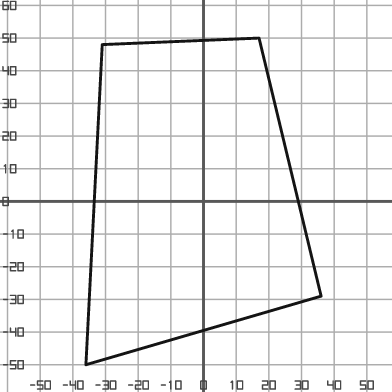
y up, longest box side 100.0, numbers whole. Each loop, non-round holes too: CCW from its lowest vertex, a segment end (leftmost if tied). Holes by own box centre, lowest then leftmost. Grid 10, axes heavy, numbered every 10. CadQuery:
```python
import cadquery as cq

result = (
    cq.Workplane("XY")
    .moveTo(-36.0, -50.0)
    .lineTo(36.0, -29.0)
    .lineTo(17.0, 50.0)
    .lineTo(-31.0, 48.0)
    .close()
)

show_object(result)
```